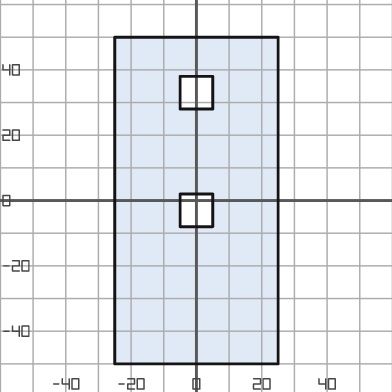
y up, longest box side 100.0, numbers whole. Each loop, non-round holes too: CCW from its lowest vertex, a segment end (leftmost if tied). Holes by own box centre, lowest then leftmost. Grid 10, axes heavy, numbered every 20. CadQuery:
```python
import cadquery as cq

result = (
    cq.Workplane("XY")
    .moveTo(-25.0, -50.0)
    .lineTo(25.0, -50.0)
    .lineTo(25.0, 50.0)
    .lineTo(-25.0, 50.0)
    .close()
    .moveTo(-5.0, -8.0)
    .lineTo(5.0, -8.0)
    .lineTo(5.0, 2.0)
    .lineTo(-5.0, 2.0)
    .close()
    .moveTo(-5.0, 28.0)
    .lineTo(5.0, 28.0)
    .lineTo(5.0, 38.0)
    .lineTo(-5.0, 38.0)
    .close()
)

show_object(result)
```